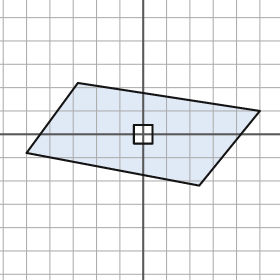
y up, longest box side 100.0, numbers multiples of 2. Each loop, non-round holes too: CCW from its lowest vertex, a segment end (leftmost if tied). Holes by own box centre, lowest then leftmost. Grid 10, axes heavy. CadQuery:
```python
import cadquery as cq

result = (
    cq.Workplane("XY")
    .moveTo(24.0, -22.0)
    .lineTo(50.0, 10.0)
    .lineTo(-28.0, 22.0)
    .lineTo(-50.0, -8.0)
    .close()
    .moveTo(-4.0, -4.0)
    .lineTo(4.0, -4.0)
    .lineTo(4.0, 4.0)
    .lineTo(-4.0, 4.0)
    .close()
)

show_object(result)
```